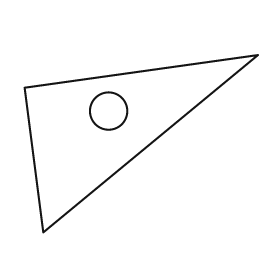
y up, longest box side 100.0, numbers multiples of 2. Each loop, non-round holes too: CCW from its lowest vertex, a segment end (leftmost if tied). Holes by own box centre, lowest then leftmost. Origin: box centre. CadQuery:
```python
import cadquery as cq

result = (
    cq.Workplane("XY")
    .moveTo(-42.0, -38.0)
    .lineTo(50.0, 38.0)
    .lineTo(-50.0, 24.0)
    .close()
    .moveTo(-14.0, 14.0)
    .circle(8.0)
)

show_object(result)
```